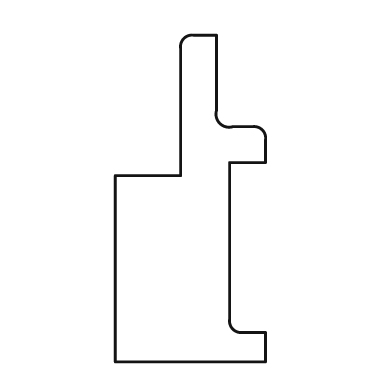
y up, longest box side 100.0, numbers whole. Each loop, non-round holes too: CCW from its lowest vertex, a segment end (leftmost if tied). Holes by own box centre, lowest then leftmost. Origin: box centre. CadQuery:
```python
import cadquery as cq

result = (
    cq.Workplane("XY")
    .moveTo(-23.0, -50.0)
    .lineTo(23.0, -50.0)
    .lineTo(23.0, -41.0)
    .lineTo(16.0, -41.0)
    .threePointArc((13.0, -40.0), (12.0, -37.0))
    .lineTo(12.0, 11.0)
    .lineTo(23.0, 11.0)
    .lineTo(23.0, 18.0)
    .threePointArc((22.0, 21.0), (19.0, 22.0))
    .lineTo(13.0, 22.0)
    .threePointArc((9.0, 23.0), (8.0, 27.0))
    .lineTo(8.0, 50.0)
    .lineTo(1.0, 50.0)
    .threePointArc((-2.0, 49.0), (-3.0, 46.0))
    .lineTo(-3.0, 7.0)
    .lineTo(-23.0, 7.0)
    .close()
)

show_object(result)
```